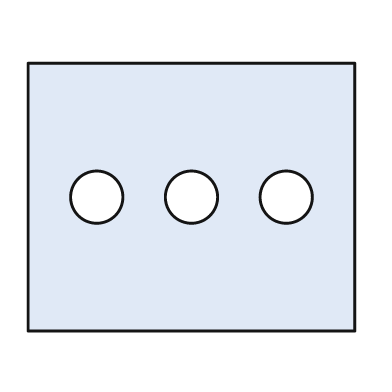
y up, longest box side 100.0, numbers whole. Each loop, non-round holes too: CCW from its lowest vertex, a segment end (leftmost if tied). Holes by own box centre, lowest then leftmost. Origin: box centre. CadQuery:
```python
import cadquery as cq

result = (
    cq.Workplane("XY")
    .moveTo(-50.0, -41.0)
    .lineTo(50.0, -41.0)
    .lineTo(50.0, 41.0)
    .lineTo(-50.0, 41.0)
    .close()
    .moveTo(-29.0, 0.0)
    .circle(8.0)
    .moveTo(0.0, 0.0)
    .circle(8.0)
    .moveTo(29.0, 0.0)
    .circle(8.0)
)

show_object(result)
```